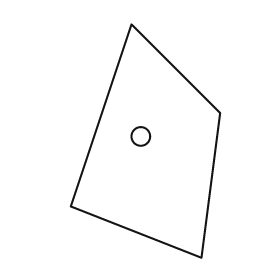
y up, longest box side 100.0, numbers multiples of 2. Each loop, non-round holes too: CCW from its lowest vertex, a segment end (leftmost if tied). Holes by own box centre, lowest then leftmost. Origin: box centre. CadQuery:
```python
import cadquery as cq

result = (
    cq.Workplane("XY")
    .moveTo(24.0, -50.0)
    .lineTo(32.0, 12.0)
    .lineTo(-6.0, 50.0)
    .lineTo(-32.0, -28.0)
    .close()
    .moveTo(-2.0, 2.0)
    .circle(4.0)
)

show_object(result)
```